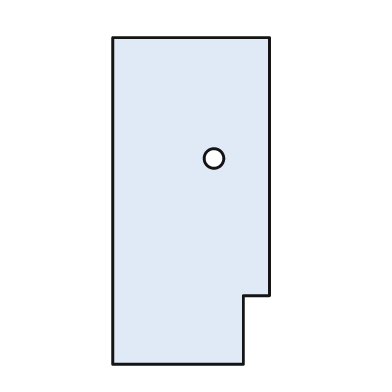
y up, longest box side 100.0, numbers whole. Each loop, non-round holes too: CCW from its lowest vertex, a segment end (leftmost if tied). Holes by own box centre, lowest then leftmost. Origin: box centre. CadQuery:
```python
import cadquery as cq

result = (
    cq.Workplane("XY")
    .moveTo(-24.0, -50.0)
    .lineTo(16.0, -50.0)
    .lineTo(16.0, -29.0)
    .lineTo(24.0, -29.0)
    .lineTo(24.0, 50.0)
    .lineTo(-24.0, 50.0)
    .close()
    .moveTo(7.0, 13.0)
    .circle(3.0)
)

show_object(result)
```